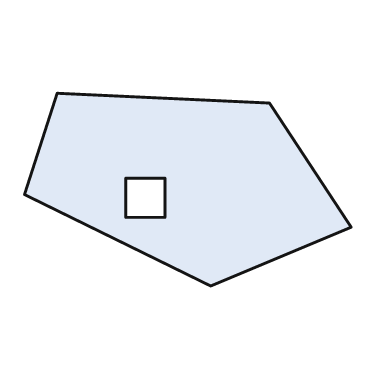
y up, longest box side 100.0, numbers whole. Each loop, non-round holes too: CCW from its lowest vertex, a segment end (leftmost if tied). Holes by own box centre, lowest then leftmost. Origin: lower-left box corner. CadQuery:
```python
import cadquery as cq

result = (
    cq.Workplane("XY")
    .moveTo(57.0, 0.0)
    .lineTo(100.0, 18.0)
    .lineTo(75.0, 56.0)
    .lineTo(10.0, 59.0)
    .lineTo(0.0, 28.0)
    .close()
    .moveTo(31.0, 21.0)
    .lineTo(43.0, 21.0)
    .lineTo(43.0, 33.0)
    .lineTo(31.0, 33.0)
    .close()
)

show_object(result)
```